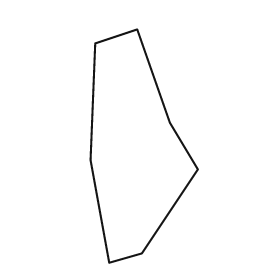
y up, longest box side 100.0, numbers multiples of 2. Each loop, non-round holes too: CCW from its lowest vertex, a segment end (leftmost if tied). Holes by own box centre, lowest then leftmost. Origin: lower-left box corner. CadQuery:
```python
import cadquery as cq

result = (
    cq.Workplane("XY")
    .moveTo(8.0, 0.0)
    .lineTo(22.0, 4.0)
    .lineTo(46.0, 40.0)
    .lineTo(34.0, 60.0)
    .lineTo(20.0, 100.0)
    .lineTo(2.0, 94.0)
    .lineTo(0.0, 44.0)
    .close()
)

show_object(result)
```